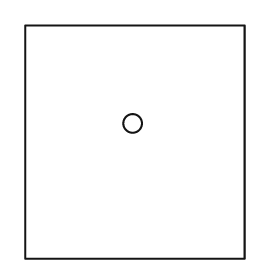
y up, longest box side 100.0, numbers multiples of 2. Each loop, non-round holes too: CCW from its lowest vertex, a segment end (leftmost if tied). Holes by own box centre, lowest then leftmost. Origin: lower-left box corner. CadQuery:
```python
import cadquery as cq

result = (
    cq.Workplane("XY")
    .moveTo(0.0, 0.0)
    .lineTo(94.0, 0.0)
    .lineTo(94.0, 100.0)
    .lineTo(0.0, 100.0)
    .close()
    .moveTo(46.0, 58.0)
    .circle(4.0)
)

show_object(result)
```